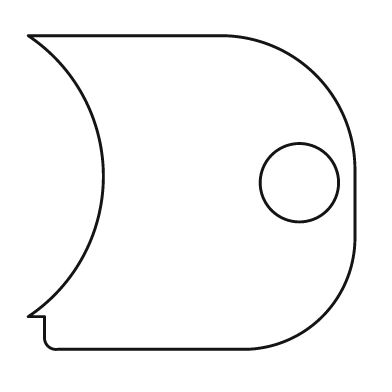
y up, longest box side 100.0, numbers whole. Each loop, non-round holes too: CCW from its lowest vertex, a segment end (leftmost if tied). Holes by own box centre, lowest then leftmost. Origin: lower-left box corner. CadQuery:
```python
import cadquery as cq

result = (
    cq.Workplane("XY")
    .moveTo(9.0, 0.0)
    .lineTo(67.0, 0.0)
    .threePointArc((90.0, 10.0), (100.0, 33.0))
    .lineTo(100.0, 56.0)
    .threePointArc((88.0, 84.0), (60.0, 96.0))
    .lineTo(0.0, 96.0)
    .threePointArc((23.0, 53.0), (0.0, 10.0))
    .lineTo(5.0, 10.0)
    .lineTo(5.0, 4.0)
    .threePointArc((6.0, 1.0), (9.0, 0.0))
    .close()
    .moveTo(83.0, 51.0)
    .circle(12.0)
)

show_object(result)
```